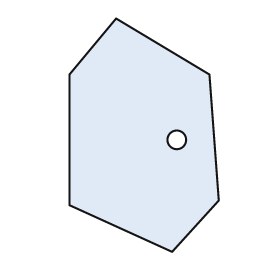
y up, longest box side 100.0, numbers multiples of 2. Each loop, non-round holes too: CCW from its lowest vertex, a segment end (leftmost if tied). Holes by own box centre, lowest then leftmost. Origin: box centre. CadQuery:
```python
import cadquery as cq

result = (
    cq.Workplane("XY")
    .moveTo(12.0, -50.0)
    .lineTo(32.0, -28.0)
    .lineTo(28.0, 26.0)
    .lineTo(-12.0, 50.0)
    .lineTo(-32.0, 26.0)
    .lineTo(-32.0, -30.0)
    .close()
    .moveTo(14.0, -2.0)
    .circle(4.0)
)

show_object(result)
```